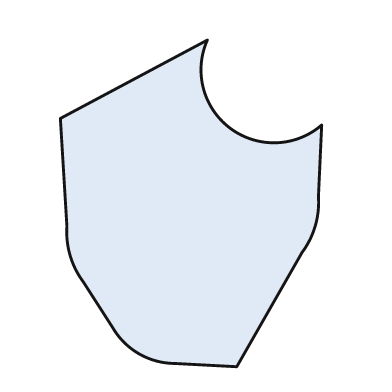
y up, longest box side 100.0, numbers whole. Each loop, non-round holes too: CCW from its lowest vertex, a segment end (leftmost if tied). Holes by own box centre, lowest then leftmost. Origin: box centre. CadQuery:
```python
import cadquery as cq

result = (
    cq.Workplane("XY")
    .moveTo(14.0, -50.0)
    .lineTo(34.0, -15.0)
    .threePointArc((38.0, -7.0), (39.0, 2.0))
    .lineTo(40.0, 24.0)
    .threePointArc((12.0, 23.0), (5.0, 50.0))
    .lineTo(-40.0, 26.0)
    .lineTo(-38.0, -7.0)
    .threePointArc((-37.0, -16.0), (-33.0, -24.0))
    .lineTo(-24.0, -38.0)
    .threePointArc((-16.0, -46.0), (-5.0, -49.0))
    .close()
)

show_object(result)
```